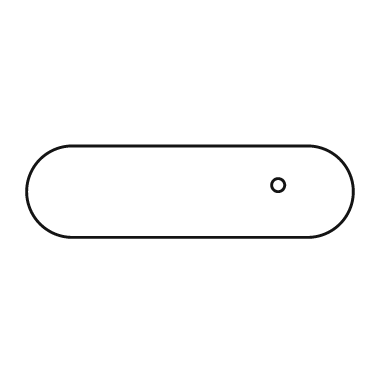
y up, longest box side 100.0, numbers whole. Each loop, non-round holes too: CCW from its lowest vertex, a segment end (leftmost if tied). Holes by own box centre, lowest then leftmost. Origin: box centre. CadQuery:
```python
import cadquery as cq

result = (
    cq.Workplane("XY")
    .moveTo(-36.0, -14.0)
    .lineTo(36.0, -14.0)
    .threePointArc((50.0, 0.0), (36.0, 14.0))
    .lineTo(-36.0, 14.0)
    .threePointArc((-50.0, 0.0), (-36.0, -14.0))
    .close()
    .moveTo(27.0, 2.0)
    .circle(2.0)
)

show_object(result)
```